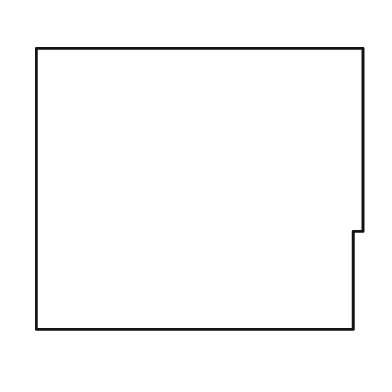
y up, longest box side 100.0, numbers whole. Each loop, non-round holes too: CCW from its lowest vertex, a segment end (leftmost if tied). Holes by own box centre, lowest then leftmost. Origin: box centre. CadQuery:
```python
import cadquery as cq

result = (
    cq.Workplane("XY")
    .moveTo(-50.0, -43.0)
    .lineTo(47.0, -43.0)
    .lineTo(47.0, -13.0)
    .lineTo(50.0, -13.0)
    .lineTo(50.0, 43.0)
    .lineTo(-50.0, 43.0)
    .close()
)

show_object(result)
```